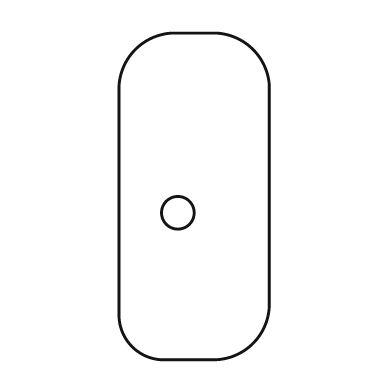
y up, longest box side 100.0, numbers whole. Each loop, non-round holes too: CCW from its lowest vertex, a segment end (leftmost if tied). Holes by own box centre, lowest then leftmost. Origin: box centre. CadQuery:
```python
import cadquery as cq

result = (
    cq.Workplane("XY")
    .moveTo(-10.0, -50.0)
    .lineTo(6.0, -50.0)
    .threePointArc((18.0, -45.0), (23.0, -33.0))
    .lineTo(23.0, 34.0)
    .threePointArc((18.0, 45.0), (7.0, 50.0))
    .lineTo(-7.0, 50.0)
    .threePointArc((-18.0, 45.0), (-23.0, 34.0))
    .lineTo(-23.0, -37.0)
    .threePointArc((-19.0, -46.0), (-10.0, -50.0))
    .close()
    .moveTo(-5.0, -5.0)
    .circle(5.0)
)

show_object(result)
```